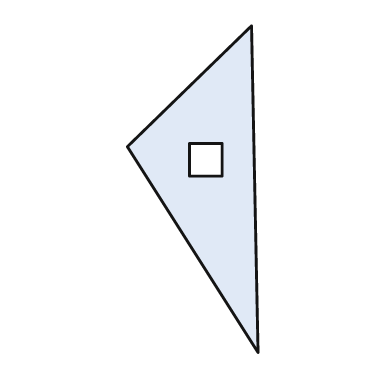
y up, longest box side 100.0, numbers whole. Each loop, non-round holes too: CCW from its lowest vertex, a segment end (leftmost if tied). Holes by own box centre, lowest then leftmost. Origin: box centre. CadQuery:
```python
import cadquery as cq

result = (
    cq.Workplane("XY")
    .moveTo(20.0, -50.0)
    .lineTo(18.0, 50.0)
    .lineTo(-20.0, 13.0)
    .close()
    .moveTo(-1.0, 4.0)
    .lineTo(9.0, 4.0)
    .lineTo(9.0, 14.0)
    .lineTo(-1.0, 14.0)
    .close()
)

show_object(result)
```